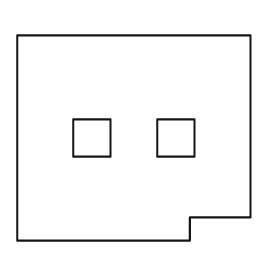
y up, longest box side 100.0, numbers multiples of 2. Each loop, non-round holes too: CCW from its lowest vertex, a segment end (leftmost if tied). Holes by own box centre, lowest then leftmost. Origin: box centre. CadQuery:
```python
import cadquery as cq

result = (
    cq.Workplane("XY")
    .moveTo(-50.0, -44.0)
    .lineTo(24.0, -44.0)
    .lineTo(24.0, -34.0)
    .lineTo(50.0, -34.0)
    .lineTo(50.0, 44.0)
    .lineTo(-50.0, 44.0)
    .close()
    .moveTo(-26.0, -8.0)
    .lineTo(-10.0, -8.0)
    .lineTo(-10.0, 8.0)
    .lineTo(-26.0, 8.0)
    .close()
    .moveTo(10.0, -8.0)
    .lineTo(26.0, -8.0)
    .lineTo(26.0, 8.0)
    .lineTo(10.0, 8.0)
    .close()
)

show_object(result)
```